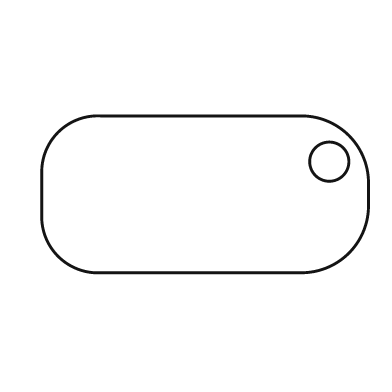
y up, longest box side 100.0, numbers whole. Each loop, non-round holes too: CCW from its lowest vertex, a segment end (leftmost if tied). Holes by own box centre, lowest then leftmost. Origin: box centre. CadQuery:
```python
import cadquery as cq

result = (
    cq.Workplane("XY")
    .moveTo(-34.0, -24.0)
    .lineTo(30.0, -24.0)
    .threePointArc((44.0, -18.0), (50.0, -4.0))
    .lineTo(50.0, 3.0)
    .threePointArc((44.0, 18.0), (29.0, 24.0))
    .lineTo(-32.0, 24.0)
    .threePointArc((-45.0, 19.0), (-50.0, 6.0))
    .lineTo(-50.0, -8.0)
    .threePointArc((-45.0, -19.0), (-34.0, -24.0))
    .close()
    .moveTo(38.0, 10.0)
    .circle(6.0)
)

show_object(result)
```